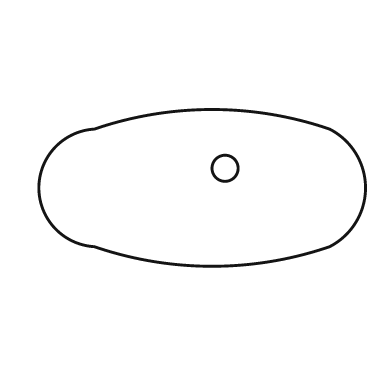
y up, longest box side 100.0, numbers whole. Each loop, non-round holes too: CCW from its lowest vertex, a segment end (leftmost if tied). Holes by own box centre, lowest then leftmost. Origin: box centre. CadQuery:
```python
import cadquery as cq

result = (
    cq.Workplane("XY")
    .moveTo(-33.0, -18.0)
    .threePointArc((3.0, -24.0), (39.0, -18.0))
    .threePointArc((50.0, 0.0), (39.0, 18.0))
    .threePointArc((3.0, 24.0), (-33.0, 18.0))
    .threePointArc((-50.0, 0.0), (-33.0, -18.0))
    .close()
    .moveTo(7.0, 6.0)
    .circle(4.0)
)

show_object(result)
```